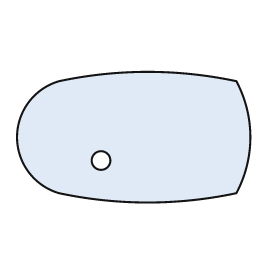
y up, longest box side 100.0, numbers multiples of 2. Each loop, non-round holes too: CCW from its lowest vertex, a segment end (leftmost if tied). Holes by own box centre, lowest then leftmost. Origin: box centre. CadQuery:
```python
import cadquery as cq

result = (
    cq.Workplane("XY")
    .moveTo(-32.0, -24.0)
    .threePointArc((6.0, -28.0), (44.0, -24.0))
    .threePointArc((50.0, 0.0), (44.0, 24.0))
    .threePointArc((6.0, 28.0), (-32.0, 24.0))
    .threePointArc((-50.0, 0.0), (-32.0, -24.0))
    .close()
    .moveTo(-14.0, -10.0)
    .circle(4.0)
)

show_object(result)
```